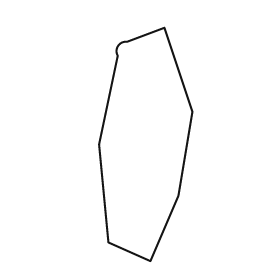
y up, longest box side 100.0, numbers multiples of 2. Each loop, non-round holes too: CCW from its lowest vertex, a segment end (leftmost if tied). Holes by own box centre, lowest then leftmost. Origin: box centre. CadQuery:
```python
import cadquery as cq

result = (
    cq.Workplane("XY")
    .moveTo(2.0, -50.0)
    .lineTo(14.0, -22.0)
    .lineTo(20.0, 14.0)
    .lineTo(8.0, 50.0)
    .lineTo(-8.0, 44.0)
    .threePointArc((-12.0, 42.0), (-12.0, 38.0))
    .lineTo(-20.0, 0.0)
    .lineTo(-16.0, -42.0)
    .close()
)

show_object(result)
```